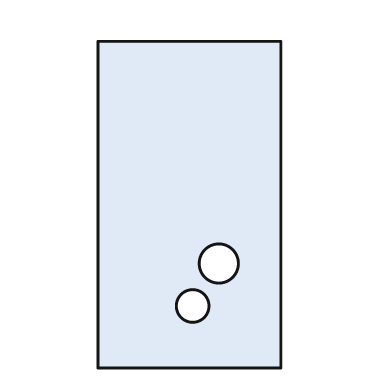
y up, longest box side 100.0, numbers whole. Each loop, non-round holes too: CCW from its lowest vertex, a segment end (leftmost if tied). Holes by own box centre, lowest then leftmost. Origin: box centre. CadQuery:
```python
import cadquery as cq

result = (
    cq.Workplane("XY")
    .moveTo(-28.0, -50.0)
    .lineTo(28.0, -50.0)
    .lineTo(28.0, 50.0)
    .lineTo(-28.0, 50.0)
    .close()
    .moveTo(1.0, -31.0)
    .circle(5.0)
    .moveTo(9.0, -18.0)
    .circle(6.0)
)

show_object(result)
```